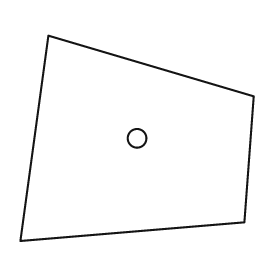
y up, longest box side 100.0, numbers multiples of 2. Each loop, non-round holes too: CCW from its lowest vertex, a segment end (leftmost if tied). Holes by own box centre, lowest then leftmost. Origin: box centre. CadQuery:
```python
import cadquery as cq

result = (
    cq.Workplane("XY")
    .moveTo(-50.0, -44.0)
    .lineTo(46.0, -36.0)
    .lineTo(50.0, 18.0)
    .lineTo(-38.0, 44.0)
    .close()
    .moveTo(0.0, 0.0)
    .circle(4.0)
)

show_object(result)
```